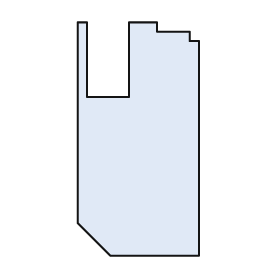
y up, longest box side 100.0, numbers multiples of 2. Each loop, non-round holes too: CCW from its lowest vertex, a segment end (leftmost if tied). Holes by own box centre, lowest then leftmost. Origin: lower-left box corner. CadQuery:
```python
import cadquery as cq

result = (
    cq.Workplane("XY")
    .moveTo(14.0, 0.0)
    .lineTo(52.0, 0.0)
    .lineTo(52.0, 92.0)
    .lineTo(48.0, 92.0)
    .lineTo(48.0, 96.0)
    .lineTo(34.0, 96.0)
    .lineTo(34.0, 100.0)
    .lineTo(22.0, 100.0)
    .lineTo(22.0, 68.0)
    .lineTo(4.0, 68.0)
    .lineTo(4.0, 100.0)
    .lineTo(0.0, 100.0)
    .lineTo(0.0, 14.0)
    .close()
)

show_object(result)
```